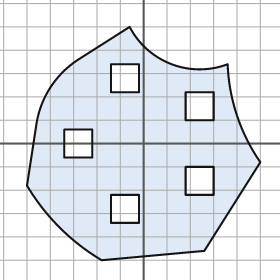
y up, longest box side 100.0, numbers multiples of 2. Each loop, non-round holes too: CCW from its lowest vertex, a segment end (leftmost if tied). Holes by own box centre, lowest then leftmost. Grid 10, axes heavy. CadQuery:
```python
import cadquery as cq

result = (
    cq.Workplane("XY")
    .moveTo(-18.0, -50.0)
    .lineTo(26.0, -46.0)
    .lineTo(50.0, -8.0)
    .threePointArc((40.0, 12.0), (36.0, 34.0))
    .threePointArc((12.0, 34.0), (-6.0, 50.0))
    .lineTo(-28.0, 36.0)
    .threePointArc((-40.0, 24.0), (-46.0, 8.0))
    .lineTo(-50.0, -18.0)
    .threePointArc((-36.0, -36.0), (-18.0, -50.0))
    .close()
    .moveTo(-14.0, -34.0)
    .lineTo(-2.0, -34.0)
    .lineTo(-2.0, -22.0)
    .lineTo(-14.0, -22.0)
    .close()
    .moveTo(18.0, -22.0)
    .lineTo(30.0, -22.0)
    .lineTo(30.0, -10.0)
    .lineTo(18.0, -10.0)
    .close()
    .moveTo(-34.0, -6.0)
    .lineTo(-22.0, -6.0)
    .lineTo(-22.0, 6.0)
    .lineTo(-34.0, 6.0)
    .close()
    .moveTo(18.0, 10.0)
    .lineTo(30.0, 10.0)
    .lineTo(30.0, 22.0)
    .lineTo(18.0, 22.0)
    .close()
    .moveTo(-14.0, 22.0)
    .lineTo(-2.0, 22.0)
    .lineTo(-2.0, 34.0)
    .lineTo(-14.0, 34.0)
    .close()
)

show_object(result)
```